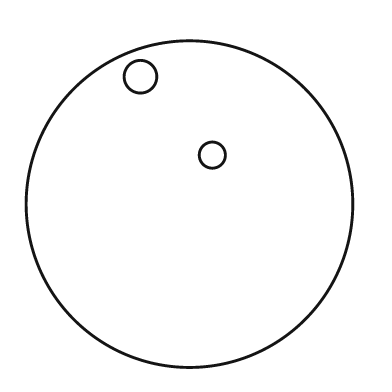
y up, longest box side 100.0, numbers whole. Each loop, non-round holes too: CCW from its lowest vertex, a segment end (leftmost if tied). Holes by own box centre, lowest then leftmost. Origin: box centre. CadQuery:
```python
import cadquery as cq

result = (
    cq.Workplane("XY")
    .moveTo(0.0, 0.0)
    .circle(50.0)
    .moveTo(7.0, 15.0)
    .circle(4.0)
    .moveTo(-15.0, 39.0)
    .circle(5.0)
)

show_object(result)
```